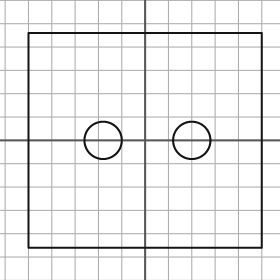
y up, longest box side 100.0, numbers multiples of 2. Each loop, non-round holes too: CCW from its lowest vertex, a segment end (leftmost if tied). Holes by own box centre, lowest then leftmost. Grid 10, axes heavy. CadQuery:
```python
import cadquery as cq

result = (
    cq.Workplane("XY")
    .moveTo(-50.0, -46.0)
    .lineTo(50.0, -46.0)
    .lineTo(50.0, 46.0)
    .lineTo(-50.0, 46.0)
    .close()
    .moveTo(-18.0, 0.0)
    .circle(8.0)
    .moveTo(20.0, 0.0)
    .circle(8.0)
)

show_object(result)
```